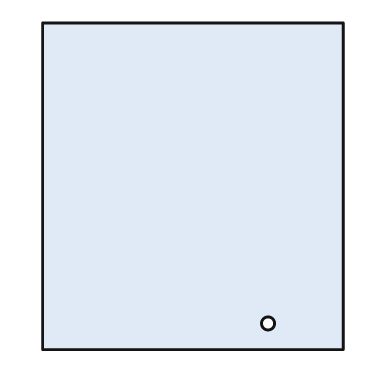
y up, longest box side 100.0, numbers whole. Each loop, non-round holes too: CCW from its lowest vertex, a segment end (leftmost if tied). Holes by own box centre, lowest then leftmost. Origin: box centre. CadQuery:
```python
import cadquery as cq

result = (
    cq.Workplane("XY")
    .moveTo(-46.0, -50.0)
    .lineTo(46.0, -50.0)
    .lineTo(46.0, 50.0)
    .lineTo(-46.0, 50.0)
    .close()
    .moveTo(23.0, -42.0)
    .circle(2.0)
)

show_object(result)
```